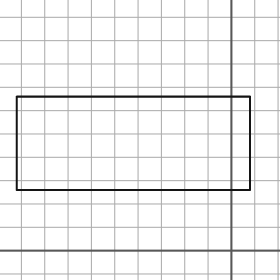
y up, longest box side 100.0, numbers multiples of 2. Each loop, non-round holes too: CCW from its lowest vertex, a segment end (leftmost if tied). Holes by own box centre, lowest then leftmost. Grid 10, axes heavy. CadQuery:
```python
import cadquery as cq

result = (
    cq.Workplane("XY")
    .moveTo(-92.0, 26.0)
    .lineTo(8.0, 26.0)
    .lineTo(8.0, 66.0)
    .lineTo(-92.0, 66.0)
    .close()
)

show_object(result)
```